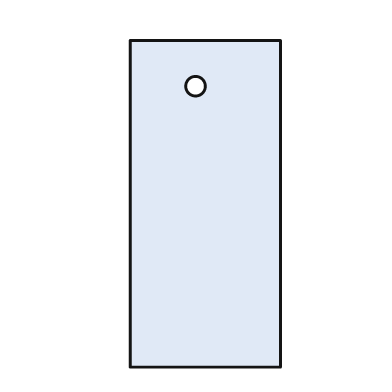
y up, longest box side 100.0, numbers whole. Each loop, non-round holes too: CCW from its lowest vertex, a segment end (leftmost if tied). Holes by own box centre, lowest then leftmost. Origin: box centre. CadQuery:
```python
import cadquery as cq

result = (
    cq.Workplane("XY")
    .moveTo(-23.0, -50.0)
    .lineTo(23.0, -50.0)
    .lineTo(23.0, 50.0)
    .lineTo(-23.0, 50.0)
    .close()
    .moveTo(-3.0, 36.0)
    .circle(3.0)
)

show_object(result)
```